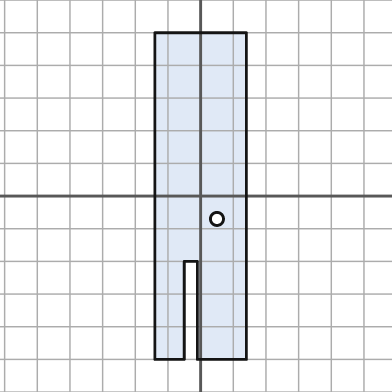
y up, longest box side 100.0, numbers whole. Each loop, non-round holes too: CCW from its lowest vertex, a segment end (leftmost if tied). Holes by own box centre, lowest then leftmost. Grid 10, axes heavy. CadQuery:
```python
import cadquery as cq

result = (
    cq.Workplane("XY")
    .moveTo(-14.0, -50.0)
    .lineTo(-5.0, -50.0)
    .lineTo(-5.0, -20.0)
    .lineTo(-1.0, -20.0)
    .lineTo(-1.0, -50.0)
    .lineTo(14.0, -50.0)
    .lineTo(14.0, 50.0)
    .lineTo(-14.0, 50.0)
    .close()
    .moveTo(5.0, -7.0)
    .circle(2.0)
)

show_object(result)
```